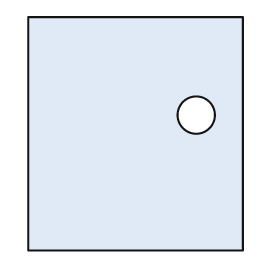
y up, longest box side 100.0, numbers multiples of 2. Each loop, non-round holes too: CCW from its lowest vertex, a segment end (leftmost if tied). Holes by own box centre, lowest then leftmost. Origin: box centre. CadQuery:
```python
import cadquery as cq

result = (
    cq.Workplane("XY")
    .moveTo(-46.0, -50.0)
    .lineTo(46.0, -50.0)
    .lineTo(46.0, 50.0)
    .lineTo(-46.0, 50.0)
    .close()
    .moveTo(26.0, 8.0)
    .circle(8.0)
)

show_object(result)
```